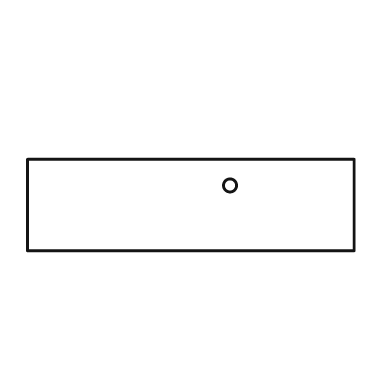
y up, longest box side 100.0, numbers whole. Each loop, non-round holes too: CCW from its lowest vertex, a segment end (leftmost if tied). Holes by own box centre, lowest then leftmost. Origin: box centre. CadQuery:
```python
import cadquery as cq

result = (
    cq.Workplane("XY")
    .moveTo(-50.0, -14.0)
    .lineTo(50.0, -14.0)
    .lineTo(50.0, 14.0)
    .lineTo(-50.0, 14.0)
    .close()
    .moveTo(12.0, 6.0)
    .circle(2.0)
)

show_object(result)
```